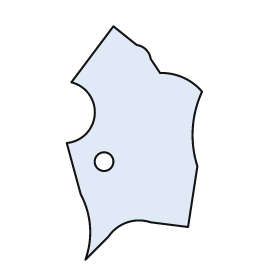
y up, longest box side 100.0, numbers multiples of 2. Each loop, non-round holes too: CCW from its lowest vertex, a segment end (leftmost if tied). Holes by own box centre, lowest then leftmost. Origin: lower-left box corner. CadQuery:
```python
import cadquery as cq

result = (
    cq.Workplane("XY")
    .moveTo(8.0, 0.0)
    .lineTo(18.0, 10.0)
    .threePointArc((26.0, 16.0), (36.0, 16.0))
    .lineTo(52.0, 14.0)
    .lineTo(56.0, 40.0)
    .threePointArc((54.0, 56.0), (58.0, 72.0))
    .threePointArc((50.0, 78.0), (40.0, 80.0))
    .lineTo(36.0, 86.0)
    .threePointArc((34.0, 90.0), (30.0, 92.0))
    .lineTo(20.0, 100.0)
    .lineTo(2.0, 76.0)
    .threePointArc((12.0, 62.0), (0.0, 50.0))
    .lineTo(6.0, 28.0)
    .threePointArc((10.0, 14.0), (8.0, 0.0))
    .close()
    .moveTo(16.0, 42.0)
    .circle(4.0)
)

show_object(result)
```